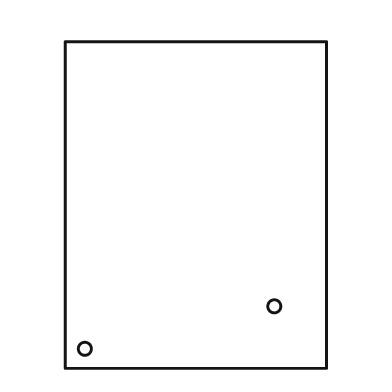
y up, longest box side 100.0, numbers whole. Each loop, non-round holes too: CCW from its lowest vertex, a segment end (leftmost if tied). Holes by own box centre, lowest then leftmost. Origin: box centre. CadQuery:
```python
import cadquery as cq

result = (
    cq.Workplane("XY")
    .moveTo(-40.0, -50.0)
    .lineTo(40.0, -50.0)
    .lineTo(40.0, 50.0)
    .lineTo(-40.0, 50.0)
    .close()
    .moveTo(-34.0, -44.0)
    .circle(2.0)
    .moveTo(24.0, -31.0)
    .circle(2.0)
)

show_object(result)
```